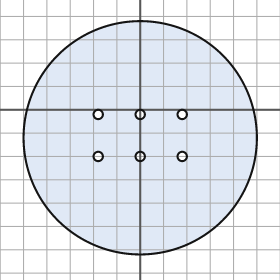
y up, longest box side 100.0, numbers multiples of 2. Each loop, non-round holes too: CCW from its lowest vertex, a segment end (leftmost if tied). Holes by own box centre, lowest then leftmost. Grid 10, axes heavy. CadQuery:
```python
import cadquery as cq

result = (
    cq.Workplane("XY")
    .moveTo(0.0, -12.0)
    .circle(50.0)
    .moveTo(-18.0, -20.0)
    .circle(2.0)
    .moveTo(0.0, -20.0)
    .circle(2.0)
    .moveTo(18.0, -20.0)
    .circle(2.0)
    .moveTo(-18.0, -2.0)
    .circle(2.0)
    .moveTo(0.0, -2.0)
    .circle(2.0)
    .moveTo(18.0, -2.0)
    .circle(2.0)
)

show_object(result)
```